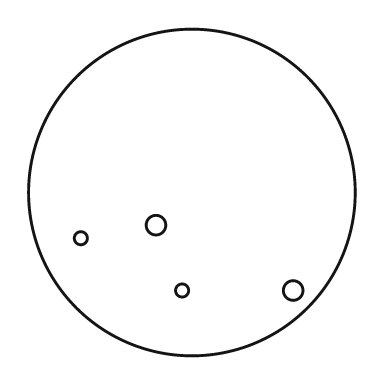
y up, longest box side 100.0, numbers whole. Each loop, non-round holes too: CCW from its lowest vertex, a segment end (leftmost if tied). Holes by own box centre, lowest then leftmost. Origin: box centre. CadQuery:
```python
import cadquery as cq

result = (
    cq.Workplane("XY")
    .moveTo(0.0, 0.0)
    .circle(50.0)
    .moveTo(-3.0, -30.0)
    .circle(2.0)
    .moveTo(31.0, -30.0)
    .circle(3.0)
    .moveTo(-34.0, -14.0)
    .circle(2.0)
    .moveTo(-11.0, -10.0)
    .circle(3.0)
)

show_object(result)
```